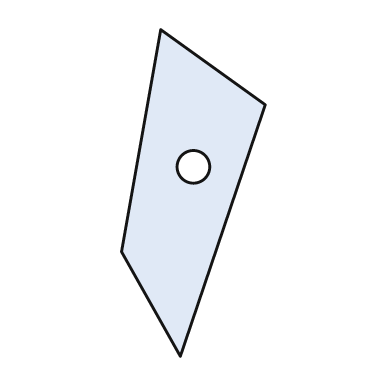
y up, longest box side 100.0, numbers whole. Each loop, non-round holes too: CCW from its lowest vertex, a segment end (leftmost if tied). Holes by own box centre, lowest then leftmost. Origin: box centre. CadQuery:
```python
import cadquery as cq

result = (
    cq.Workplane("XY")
    .moveTo(-4.0, -50.0)
    .lineTo(22.0, 27.0)
    .lineTo(-10.0, 50.0)
    .lineTo(-22.0, -18.0)
    .close()
    .moveTo(0.0, 8.0)
    .circle(5.0)
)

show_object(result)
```